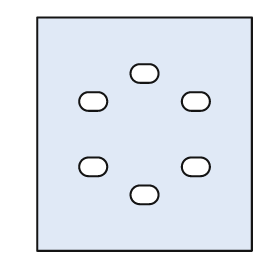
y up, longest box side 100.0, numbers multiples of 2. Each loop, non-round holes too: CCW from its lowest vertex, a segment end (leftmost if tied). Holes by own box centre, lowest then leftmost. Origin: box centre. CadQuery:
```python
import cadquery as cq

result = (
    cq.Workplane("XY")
    .moveTo(-46.0, -50.0)
    .lineTo(46.0, -50.0)
    .lineTo(46.0, 50.0)
    .lineTo(-46.0, 50.0)
    .close()
    .moveTo(-2.0, -30.0)
    .lineTo(2.0, -30.0)
    .threePointArc((6.0, -26.0), (2.0, -22.0))
    .lineTo(-2.0, -22.0)
    .threePointArc((-6.0, -26.0), (-2.0, -30.0))
    .close()
    .moveTo(-24.0, -18.0)
    .lineTo(-20.0, -18.0)
    .threePointArc((-16.0, -14.0), (-20.0, -10.0))
    .lineTo(-24.0, -10.0)
    .threePointArc((-28.0, -14.0), (-24.0, -18.0))
    .close()
    .moveTo(20.0, -18.0)
    .lineTo(24.0, -18.0)
    .threePointArc((28.0, -14.0), (24.0, -10.0))
    .lineTo(20.0, -10.0)
    .threePointArc((16.0, -14.0), (20.0, -18.0))
    .close()
    .moveTo(-24.0, 10.0)
    .lineTo(-20.0, 10.0)
    .threePointArc((-16.0, 14.0), (-20.0, 18.0))
    .lineTo(-24.0, 18.0)
    .threePointArc((-28.0, 14.0), (-24.0, 10.0))
    .close()
    .moveTo(20.0, 10.0)
    .lineTo(24.0, 10.0)
    .threePointArc((28.0, 14.0), (24.0, 18.0))
    .lineTo(20.0, 18.0)
    .threePointArc((16.0, 14.0), (20.0, 10.0))
    .close()
    .moveTo(-2.0, 22.0)
    .lineTo(2.0, 22.0)
    .threePointArc((6.0, 26.0), (2.0, 30.0))
    .lineTo(-2.0, 30.0)
    .threePointArc((-6.0, 26.0), (-2.0, 22.0))
    .close()
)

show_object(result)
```